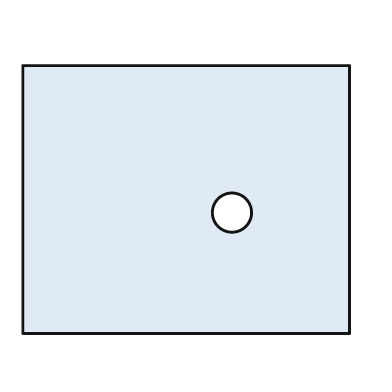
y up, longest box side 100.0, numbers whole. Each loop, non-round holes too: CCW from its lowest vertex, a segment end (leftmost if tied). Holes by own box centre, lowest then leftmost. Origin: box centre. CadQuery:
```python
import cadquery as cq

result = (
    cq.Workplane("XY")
    .moveTo(-50.0, -41.0)
    .lineTo(50.0, -41.0)
    .lineTo(50.0, 41.0)
    .lineTo(-50.0, 41.0)
    .close()
    .moveTo(14.0, -4.0)
    .circle(6.0)
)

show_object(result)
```